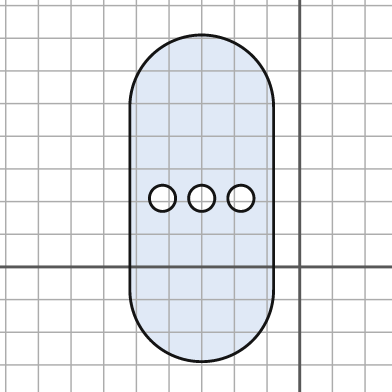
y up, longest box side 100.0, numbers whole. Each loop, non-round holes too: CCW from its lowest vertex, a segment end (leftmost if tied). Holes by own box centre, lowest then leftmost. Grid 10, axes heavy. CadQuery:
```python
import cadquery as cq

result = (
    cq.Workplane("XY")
    .moveTo(-52.0, -7.0)
    .threePointArc((-30.0, -29.0), (-8.0, -7.0))
    .lineTo(-8.0, 49.0)
    .threePointArc((-30.0, 71.0), (-52.0, 49.0))
    .close()
    .moveTo(-42.0, 21.0)
    .circle(4.0)
    .moveTo(-30.0, 21.0)
    .circle(4.0)
    .moveTo(-18.0, 21.0)
    .circle(4.0)
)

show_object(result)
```